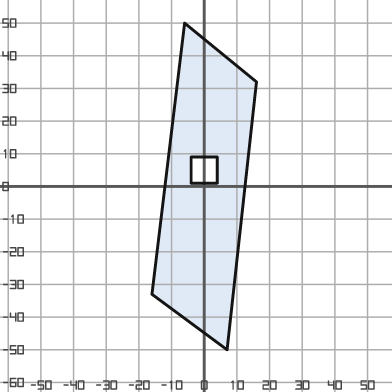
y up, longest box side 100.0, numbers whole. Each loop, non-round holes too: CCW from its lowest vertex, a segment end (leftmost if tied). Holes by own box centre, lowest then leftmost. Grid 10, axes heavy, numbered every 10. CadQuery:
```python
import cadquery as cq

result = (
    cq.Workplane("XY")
    .moveTo(7.0, -50.0)
    .lineTo(16.0, 32.0)
    .lineTo(-6.0, 50.0)
    .lineTo(-16.0, -33.0)
    .close()
    .moveTo(-4.0, 1.0)
    .lineTo(4.0, 1.0)
    .lineTo(4.0, 9.0)
    .lineTo(-4.0, 9.0)
    .close()
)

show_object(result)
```